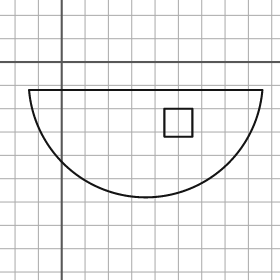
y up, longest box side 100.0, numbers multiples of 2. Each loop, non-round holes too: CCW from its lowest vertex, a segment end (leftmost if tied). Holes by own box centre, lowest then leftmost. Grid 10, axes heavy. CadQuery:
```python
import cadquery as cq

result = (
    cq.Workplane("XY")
    .moveTo(-14.0, -12.0)
    .threePointArc((36.0, -58.0), (86.0, -12.0))
    .close()
    .moveTo(44.0, -32.0)
    .lineTo(56.0, -32.0)
    .lineTo(56.0, -20.0)
    .lineTo(44.0, -20.0)
    .close()
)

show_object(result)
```